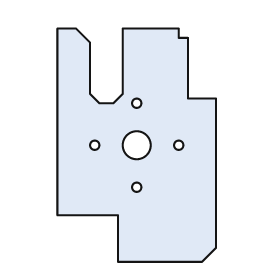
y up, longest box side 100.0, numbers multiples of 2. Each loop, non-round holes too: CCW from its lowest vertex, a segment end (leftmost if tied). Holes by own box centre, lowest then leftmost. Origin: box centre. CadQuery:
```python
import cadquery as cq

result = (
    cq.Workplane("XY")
    .moveTo(-8.0, -50.0)
    .lineTo(28.0, -50.0)
    .lineTo(34.0, -44.0)
    .lineTo(34.0, 20.0)
    .lineTo(22.0, 20.0)
    .lineTo(22.0, 46.0)
    .lineTo(18.0, 46.0)
    .lineTo(18.0, 50.0)
    .lineTo(-6.0, 50.0)
    .lineTo(-6.0, 22.0)
    .lineTo(-10.0, 18.0)
    .lineTo(-16.0, 18.0)
    .lineTo(-20.0, 22.0)
    .lineTo(-20.0, 44.0)
    .lineTo(-26.0, 50.0)
    .lineTo(-34.0, 50.0)
    .lineTo(-34.0, -30.0)
    .lineTo(-8.0, -30.0)
    .close()
    .moveTo(0.0, -18.0)
    .circle(2.0)
    .moveTo(-18.0, 0.0)
    .circle(2.0)
    .moveTo(0.0, 0.0)
    .circle(6.0)
    .moveTo(18.0, 0.0)
    .circle(2.0)
    .moveTo(0.0, 18.0)
    .circle(2.0)
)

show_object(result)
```